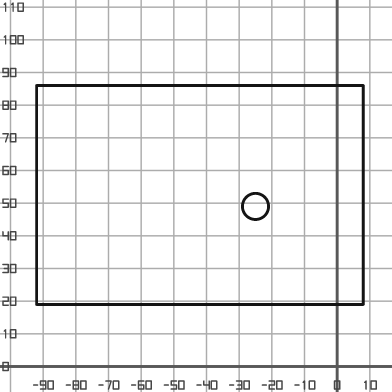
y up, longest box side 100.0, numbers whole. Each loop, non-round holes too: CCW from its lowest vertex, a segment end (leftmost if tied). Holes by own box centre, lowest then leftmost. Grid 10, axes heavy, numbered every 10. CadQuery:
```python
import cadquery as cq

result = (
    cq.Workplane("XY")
    .moveTo(-92.0, 19.0)
    .lineTo(8.0, 19.0)
    .lineTo(8.0, 86.0)
    .lineTo(-92.0, 86.0)
    .close()
    .moveTo(-25.0, 49.0)
    .circle(4.0)
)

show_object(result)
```